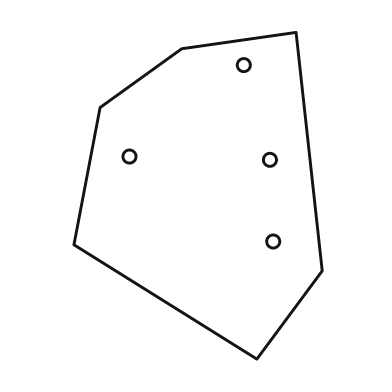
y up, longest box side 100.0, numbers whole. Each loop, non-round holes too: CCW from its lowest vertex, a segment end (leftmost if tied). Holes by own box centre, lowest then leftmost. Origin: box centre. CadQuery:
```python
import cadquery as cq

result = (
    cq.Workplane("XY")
    .moveTo(18.0, -50.0)
    .lineTo(38.0, -23.0)
    .lineTo(30.0, 50.0)
    .lineTo(-5.0, 45.0)
    .lineTo(-30.0, 27.0)
    .lineTo(-38.0, -15.0)
    .close()
    .moveTo(23.0, -14.0)
    .circle(2.0)
    .moveTo(22.0, 11.0)
    .circle(2.0)
    .moveTo(-21.0, 12.0)
    .circle(2.0)
    .moveTo(14.0, 40.0)
    .circle(2.0)
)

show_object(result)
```